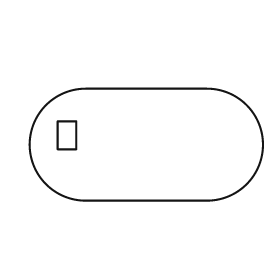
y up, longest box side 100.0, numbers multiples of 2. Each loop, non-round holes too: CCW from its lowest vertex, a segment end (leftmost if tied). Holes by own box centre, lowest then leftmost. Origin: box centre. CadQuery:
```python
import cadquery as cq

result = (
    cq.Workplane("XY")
    .moveTo(-26.0, -24.0)
    .lineTo(26.0, -24.0)
    .threePointArc((50.0, 0.0), (26.0, 24.0))
    .lineTo(-26.0, 24.0)
    .threePointArc((-50.0, 0.0), (-26.0, -24.0))
    .close()
    .moveTo(-38.0, -2.0)
    .lineTo(-30.0, -2.0)
    .lineTo(-30.0, 10.0)
    .lineTo(-38.0, 10.0)
    .close()
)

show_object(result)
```